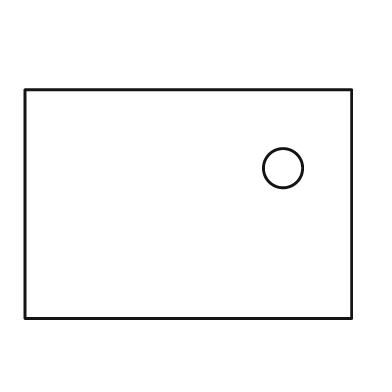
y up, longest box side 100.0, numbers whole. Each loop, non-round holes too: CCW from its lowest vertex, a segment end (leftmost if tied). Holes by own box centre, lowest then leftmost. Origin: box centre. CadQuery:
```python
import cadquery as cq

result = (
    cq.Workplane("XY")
    .moveTo(-50.0, -35.0)
    .lineTo(50.0, -35.0)
    .lineTo(50.0, 35.0)
    .lineTo(-50.0, 35.0)
    .close()
    .moveTo(29.0, 11.0)
    .circle(6.0)
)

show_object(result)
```